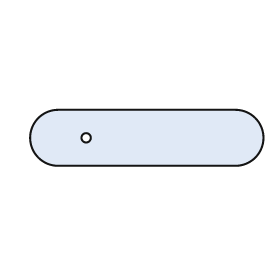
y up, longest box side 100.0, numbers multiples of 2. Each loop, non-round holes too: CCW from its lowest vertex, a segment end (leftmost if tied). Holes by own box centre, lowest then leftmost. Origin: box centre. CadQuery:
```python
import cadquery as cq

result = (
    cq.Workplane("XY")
    .moveTo(-38.0, -12.0)
    .lineTo(38.0, -12.0)
    .threePointArc((50.0, 0.0), (38.0, 12.0))
    .lineTo(-38.0, 12.0)
    .threePointArc((-50.0, 0.0), (-38.0, -12.0))
    .close()
    .moveTo(-26.0, 0.0)
    .circle(2.0)
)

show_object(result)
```